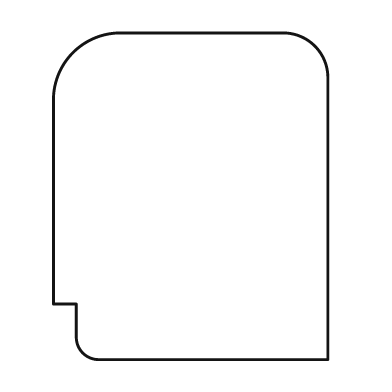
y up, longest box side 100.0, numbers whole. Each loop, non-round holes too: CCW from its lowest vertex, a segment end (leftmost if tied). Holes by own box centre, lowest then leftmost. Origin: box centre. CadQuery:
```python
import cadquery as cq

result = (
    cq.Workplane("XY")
    .moveTo(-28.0, -50.0)
    .lineTo(42.0, -50.0)
    .lineTo(42.0, 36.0)
    .threePointArc((38.0, 46.0), (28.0, 50.0))
    .lineTo(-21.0, 50.0)
    .threePointArc((-36.0, 44.0), (-42.0, 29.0))
    .lineTo(-42.0, -33.0)
    .lineTo(-35.0, -33.0)
    .lineTo(-35.0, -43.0)
    .threePointArc((-33.0, -48.0), (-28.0, -50.0))
    .close()
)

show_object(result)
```